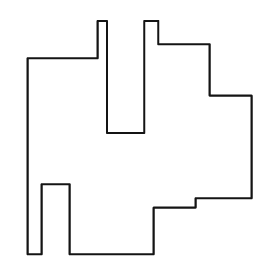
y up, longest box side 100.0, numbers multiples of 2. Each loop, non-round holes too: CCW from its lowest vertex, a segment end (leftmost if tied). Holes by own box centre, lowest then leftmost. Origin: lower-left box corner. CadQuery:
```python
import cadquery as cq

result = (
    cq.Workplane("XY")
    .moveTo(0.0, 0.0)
    .lineTo(6.0, 0.0)
    .lineTo(6.0, 30.0)
    .lineTo(18.0, 30.0)
    .lineTo(18.0, 0.0)
    .lineTo(54.0, 0.0)
    .lineTo(54.0, 20.0)
    .lineTo(72.0, 20.0)
    .lineTo(72.0, 24.0)
    .lineTo(96.0, 24.0)
    .lineTo(96.0, 68.0)
    .lineTo(78.0, 68.0)
    .lineTo(78.0, 90.0)
    .lineTo(56.0, 90.0)
    .lineTo(56.0, 100.0)
    .lineTo(50.0, 100.0)
    .lineTo(50.0, 52.0)
    .lineTo(34.0, 52.0)
    .lineTo(34.0, 100.0)
    .lineTo(30.0, 100.0)
    .lineTo(30.0, 84.0)
    .lineTo(0.0, 84.0)
    .close()
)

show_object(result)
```